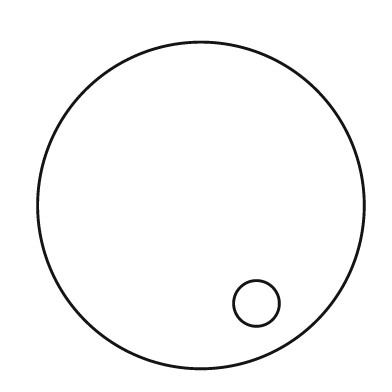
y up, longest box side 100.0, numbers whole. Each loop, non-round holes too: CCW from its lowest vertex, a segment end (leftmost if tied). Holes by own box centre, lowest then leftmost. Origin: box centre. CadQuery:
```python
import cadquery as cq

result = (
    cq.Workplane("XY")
    .moveTo(0.0, 0.0)
    .circle(50.0)
    .moveTo(17.0, -30.0)
    .circle(7.0)
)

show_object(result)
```